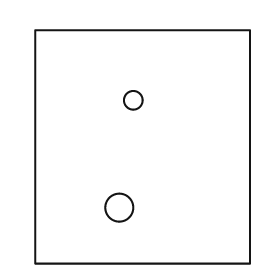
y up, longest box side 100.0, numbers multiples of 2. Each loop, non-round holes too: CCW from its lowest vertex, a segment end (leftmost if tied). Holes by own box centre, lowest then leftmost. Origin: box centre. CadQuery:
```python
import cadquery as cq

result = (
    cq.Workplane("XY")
    .moveTo(-46.0, -50.0)
    .lineTo(46.0, -50.0)
    .lineTo(46.0, 50.0)
    .lineTo(-46.0, 50.0)
    .close()
    .moveTo(-10.0, -26.0)
    .circle(6.0)
    .moveTo(-4.0, 20.0)
    .circle(4.0)
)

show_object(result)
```